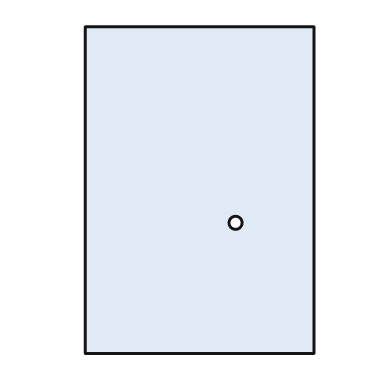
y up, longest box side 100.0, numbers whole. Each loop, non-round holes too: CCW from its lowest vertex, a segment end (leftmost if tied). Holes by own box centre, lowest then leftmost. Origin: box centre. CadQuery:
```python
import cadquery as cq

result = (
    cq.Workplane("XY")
    .moveTo(-35.0, -50.0)
    .lineTo(35.0, -50.0)
    .lineTo(35.0, 50.0)
    .lineTo(-35.0, 50.0)
    .close()
    .moveTo(11.0, -10.0)
    .circle(2.0)
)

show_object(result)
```